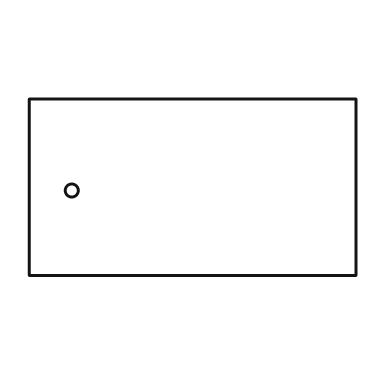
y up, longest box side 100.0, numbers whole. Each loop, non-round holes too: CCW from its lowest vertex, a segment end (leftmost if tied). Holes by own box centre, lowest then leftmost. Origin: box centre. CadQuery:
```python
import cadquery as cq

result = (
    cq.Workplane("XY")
    .moveTo(-50.0, -27.0)
    .lineTo(50.0, -27.0)
    .lineTo(50.0, 27.0)
    .lineTo(-50.0, 27.0)
    .close()
    .moveTo(-37.0, -1.0)
    .circle(2.0)
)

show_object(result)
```